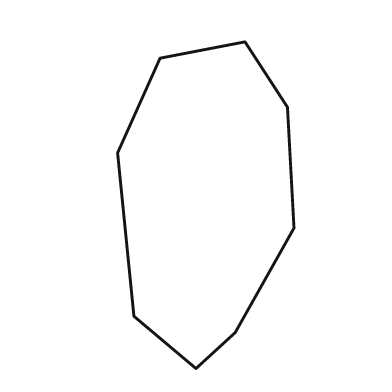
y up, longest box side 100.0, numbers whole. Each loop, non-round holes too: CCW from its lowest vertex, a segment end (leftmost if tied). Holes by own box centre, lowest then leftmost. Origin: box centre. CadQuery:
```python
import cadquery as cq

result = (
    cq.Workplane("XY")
    .moveTo(-3.0, -50.0)
    .lineTo(9.0, -39.0)
    .lineTo(27.0, -7.0)
    .lineTo(25.0, 30.0)
    .lineTo(12.0, 50.0)
    .lineTo(-14.0, 45.0)
    .lineTo(-27.0, 16.0)
    .lineTo(-22.0, -34.0)
    .close()
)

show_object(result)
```